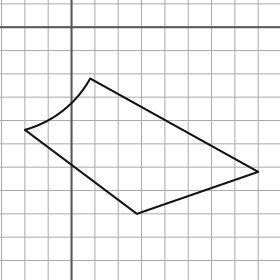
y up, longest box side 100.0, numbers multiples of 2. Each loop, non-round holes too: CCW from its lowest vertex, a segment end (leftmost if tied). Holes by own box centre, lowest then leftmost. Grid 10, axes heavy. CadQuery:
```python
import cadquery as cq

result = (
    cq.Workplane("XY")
    .moveTo(28.0, -80.0)
    .lineTo(80.0, -62.0)
    .lineTo(8.0, -22.0)
    .threePointArc((-4.0, -36.0), (-20.0, -44.0))
    .close()
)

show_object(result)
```